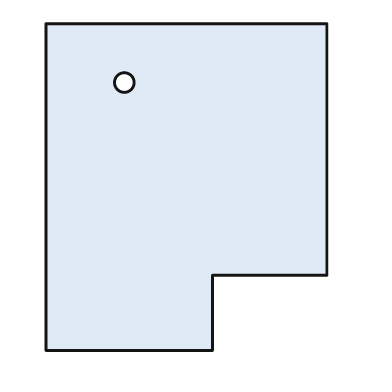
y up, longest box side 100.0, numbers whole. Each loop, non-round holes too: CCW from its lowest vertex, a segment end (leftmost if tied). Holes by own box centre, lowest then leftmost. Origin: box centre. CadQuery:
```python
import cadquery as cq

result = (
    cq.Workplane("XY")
    .moveTo(-43.0, -50.0)
    .lineTo(8.0, -50.0)
    .lineTo(8.0, -27.0)
    .lineTo(43.0, -27.0)
    .lineTo(43.0, 50.0)
    .lineTo(-43.0, 50.0)
    .close()
    .moveTo(-19.0, 32.0)
    .circle(3.0)
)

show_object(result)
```